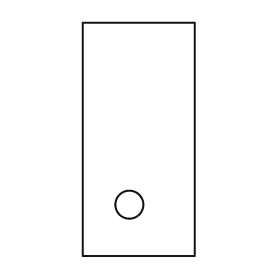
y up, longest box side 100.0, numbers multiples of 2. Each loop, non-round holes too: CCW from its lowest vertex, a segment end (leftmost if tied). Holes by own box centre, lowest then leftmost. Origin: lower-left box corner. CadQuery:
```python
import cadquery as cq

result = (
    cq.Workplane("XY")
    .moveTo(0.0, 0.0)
    .lineTo(48.0, 0.0)
    .lineTo(48.0, 100.0)
    .lineTo(0.0, 100.0)
    .close()
    .moveTo(20.0, 22.0)
    .circle(6.0)
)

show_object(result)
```